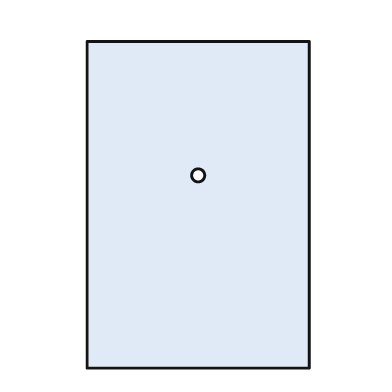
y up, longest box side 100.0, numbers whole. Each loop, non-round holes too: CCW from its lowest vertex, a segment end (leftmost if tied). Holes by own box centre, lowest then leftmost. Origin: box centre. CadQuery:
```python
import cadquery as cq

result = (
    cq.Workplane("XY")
    .moveTo(-34.0, -50.0)
    .lineTo(34.0, -50.0)
    .lineTo(34.0, 50.0)
    .lineTo(-34.0, 50.0)
    .close()
    .moveTo(0.0, 9.0)
    .circle(2.0)
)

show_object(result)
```